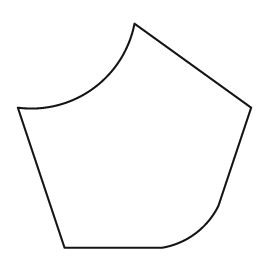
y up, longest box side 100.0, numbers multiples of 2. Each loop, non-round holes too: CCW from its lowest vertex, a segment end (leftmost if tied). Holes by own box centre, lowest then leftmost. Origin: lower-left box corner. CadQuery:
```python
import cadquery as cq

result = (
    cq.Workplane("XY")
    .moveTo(20.0, 0.0)
    .lineTo(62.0, 0.0)
    .threePointArc((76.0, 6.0), (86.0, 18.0))
    .lineTo(100.0, 60.0)
    .lineTo(50.0, 96.0)
    .threePointArc((32.0, 68.0), (0.0, 60.0))
    .close()
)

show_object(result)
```